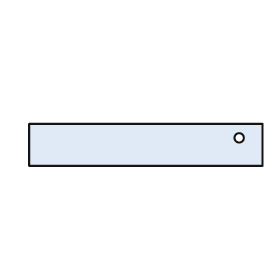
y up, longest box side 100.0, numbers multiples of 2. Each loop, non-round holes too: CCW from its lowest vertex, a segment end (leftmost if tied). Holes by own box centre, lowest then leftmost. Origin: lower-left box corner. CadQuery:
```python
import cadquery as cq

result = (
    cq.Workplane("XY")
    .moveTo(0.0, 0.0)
    .lineTo(100.0, 0.0)
    .lineTo(100.0, 18.0)
    .lineTo(0.0, 18.0)
    .close()
    .moveTo(90.0, 12.0)
    .circle(2.0)
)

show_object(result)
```